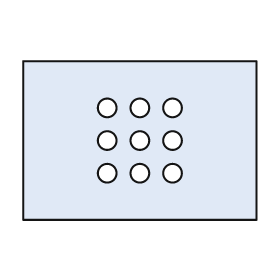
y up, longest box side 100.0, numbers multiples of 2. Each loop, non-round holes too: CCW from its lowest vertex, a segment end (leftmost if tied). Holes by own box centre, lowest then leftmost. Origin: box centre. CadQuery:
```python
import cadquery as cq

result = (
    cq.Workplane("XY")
    .moveTo(-50.0, -34.0)
    .lineTo(50.0, -34.0)
    .lineTo(50.0, 34.0)
    .lineTo(-50.0, 34.0)
    .close()
    .moveTo(-14.0, -14.0)
    .circle(4.0)
    .moveTo(0.0, -14.0)
    .circle(4.0)
    .moveTo(14.0, -14.0)
    .circle(4.0)
    .moveTo(-14.0, 0.0)
    .circle(4.0)
    .moveTo(0.0, 0.0)
    .circle(4.0)
    .moveTo(14.0, 0.0)
    .circle(4.0)
    .moveTo(-14.0, 14.0)
    .circle(4.0)
    .moveTo(0.0, 14.0)
    .circle(4.0)
    .moveTo(14.0, 14.0)
    .circle(4.0)
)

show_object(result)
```